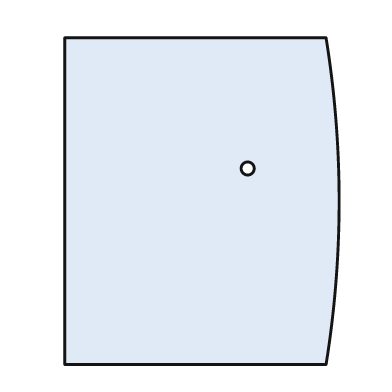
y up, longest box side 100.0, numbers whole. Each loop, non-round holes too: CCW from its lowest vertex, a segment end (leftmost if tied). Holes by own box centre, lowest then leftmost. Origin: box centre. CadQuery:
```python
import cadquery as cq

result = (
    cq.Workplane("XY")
    .moveTo(-42.0, -50.0)
    .lineTo(38.0, -50.0)
    .threePointArc((42.0, 0.0), (38.0, 50.0))
    .lineTo(-42.0, 50.0)
    .close()
    .moveTo(14.0, 10.0)
    .circle(2.0)
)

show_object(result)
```